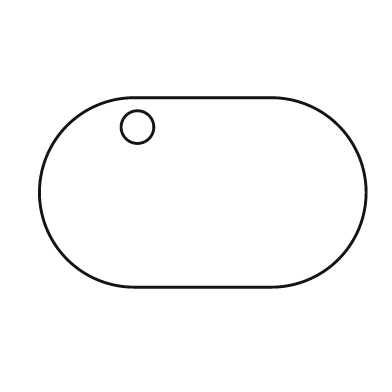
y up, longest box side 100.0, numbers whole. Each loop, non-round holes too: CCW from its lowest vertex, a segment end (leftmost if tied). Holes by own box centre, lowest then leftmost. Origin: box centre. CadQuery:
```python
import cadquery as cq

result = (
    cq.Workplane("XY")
    .moveTo(-21.0, -29.0)
    .lineTo(21.0, -29.0)
    .threePointArc((50.0, 0.0), (21.0, 29.0))
    .lineTo(-21.0, 29.0)
    .threePointArc((-50.0, 0.0), (-21.0, -29.0))
    .close()
    .moveTo(-20.0, 20.0)
    .circle(5.0)
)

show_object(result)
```